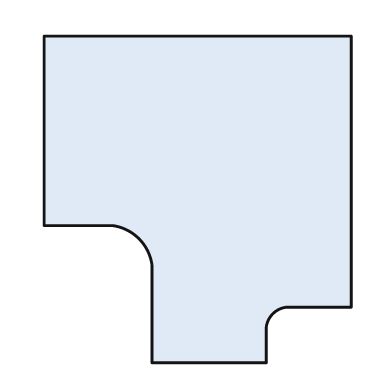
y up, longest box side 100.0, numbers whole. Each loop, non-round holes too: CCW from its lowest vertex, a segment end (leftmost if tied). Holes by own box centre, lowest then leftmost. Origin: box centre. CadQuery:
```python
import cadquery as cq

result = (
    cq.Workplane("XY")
    .moveTo(-14.0, -50.0)
    .lineTo(21.0, -50.0)
    .lineTo(21.0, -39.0)
    .threePointArc((23.0, -35.0), (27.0, -33.0))
    .lineTo(47.0, -33.0)
    .lineTo(47.0, 50.0)
    .lineTo(-47.0, 50.0)
    .lineTo(-47.0, -8.0)
    .lineTo(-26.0, -8.0)
    .threePointArc((-18.0, -12.0), (-14.0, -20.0))
    .close()
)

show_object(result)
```